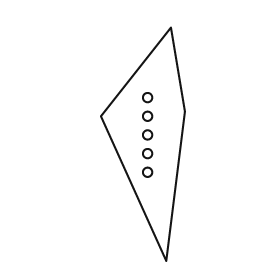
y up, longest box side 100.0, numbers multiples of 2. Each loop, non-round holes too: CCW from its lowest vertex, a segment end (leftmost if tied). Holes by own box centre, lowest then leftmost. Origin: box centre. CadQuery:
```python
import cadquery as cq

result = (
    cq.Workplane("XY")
    .moveTo(10.0, -50.0)
    .lineTo(18.0, 14.0)
    .lineTo(12.0, 50.0)
    .lineTo(-18.0, 12.0)
    .close()
    .moveTo(2.0, -12.0)
    .circle(2.0)
    .moveTo(2.0, -4.0)
    .circle(2.0)
    .moveTo(2.0, 4.0)
    .circle(2.0)
    .moveTo(2.0, 12.0)
    .circle(2.0)
    .moveTo(2.0, 20.0)
    .circle(2.0)
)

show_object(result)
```